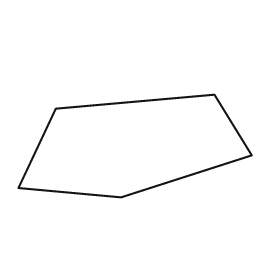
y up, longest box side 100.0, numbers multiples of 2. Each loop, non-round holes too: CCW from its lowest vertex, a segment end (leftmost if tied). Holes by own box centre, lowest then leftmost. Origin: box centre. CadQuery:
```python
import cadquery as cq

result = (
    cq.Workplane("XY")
    .moveTo(-6.0, -22.0)
    .lineTo(50.0, -4.0)
    .lineTo(34.0, 22.0)
    .lineTo(-34.0, 16.0)
    .lineTo(-50.0, -18.0)
    .close()
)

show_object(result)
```